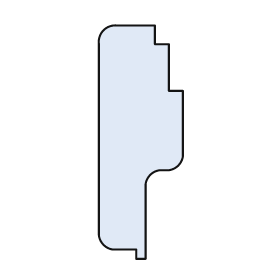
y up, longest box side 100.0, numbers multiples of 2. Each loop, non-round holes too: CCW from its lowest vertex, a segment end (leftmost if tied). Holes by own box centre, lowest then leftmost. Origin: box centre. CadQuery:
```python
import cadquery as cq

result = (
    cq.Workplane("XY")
    .moveTo(-2.0, -50.0)
    .lineTo(2.0, -50.0)
    .lineTo(2.0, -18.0)
    .threePointArc((4.0, -14.0), (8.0, -12.0))
    .lineTo(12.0, -12.0)
    .threePointArc((16.0, -10.0), (18.0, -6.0))
    .lineTo(18.0, 22.0)
    .lineTo(12.0, 22.0)
    .lineTo(12.0, 42.0)
    .lineTo(6.0, 42.0)
    .lineTo(6.0, 50.0)
    .lineTo(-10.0, 50.0)
    .threePointArc((-16.0, 48.0), (-18.0, 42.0))
    .lineTo(-18.0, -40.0)
    .threePointArc((-16.0, -44.0), (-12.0, -46.0))
    .lineTo(-2.0, -46.0)
    .close()
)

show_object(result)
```